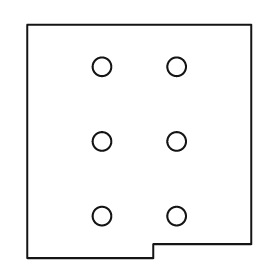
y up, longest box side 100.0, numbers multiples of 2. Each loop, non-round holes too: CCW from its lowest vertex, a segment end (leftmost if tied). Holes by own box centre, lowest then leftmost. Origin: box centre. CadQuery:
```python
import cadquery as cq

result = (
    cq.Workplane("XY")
    .moveTo(-48.0, -50.0)
    .lineTo(6.0, -50.0)
    .lineTo(6.0, -44.0)
    .lineTo(48.0, -44.0)
    .lineTo(48.0, 50.0)
    .lineTo(-48.0, 50.0)
    .close()
    .moveTo(-16.0, -32.0)
    .circle(4.0)
    .moveTo(16.0, -32.0)
    .circle(4.0)
    .moveTo(-16.0, 0.0)
    .circle(4.0)
    .moveTo(16.0, 0.0)
    .circle(4.0)
    .moveTo(-16.0, 32.0)
    .circle(4.0)
    .moveTo(16.0, 32.0)
    .circle(4.0)
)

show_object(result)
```